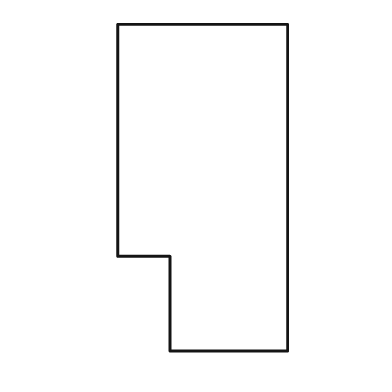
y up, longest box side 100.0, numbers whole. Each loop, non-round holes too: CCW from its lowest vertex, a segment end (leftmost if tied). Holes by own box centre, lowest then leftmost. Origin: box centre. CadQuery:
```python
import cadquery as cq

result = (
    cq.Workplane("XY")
    .moveTo(-10.0, -50.0)
    .lineTo(26.0, -50.0)
    .lineTo(26.0, 50.0)
    .lineTo(-26.0, 50.0)
    .lineTo(-26.0, -21.0)
    .lineTo(-10.0, -21.0)
    .close()
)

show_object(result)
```